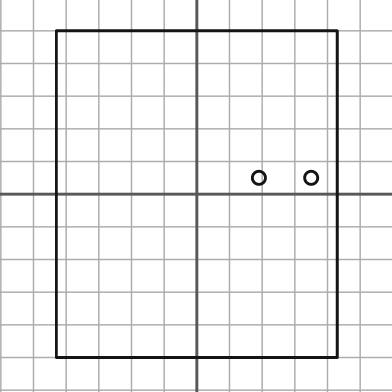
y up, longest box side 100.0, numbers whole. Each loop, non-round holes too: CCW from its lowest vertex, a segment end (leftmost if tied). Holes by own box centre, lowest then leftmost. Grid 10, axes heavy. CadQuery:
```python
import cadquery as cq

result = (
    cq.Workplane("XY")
    .moveTo(-43.0, -50.0)
    .lineTo(43.0, -50.0)
    .lineTo(43.0, 50.0)
    .lineTo(-43.0, 50.0)
    .close()
    .moveTo(19.0, 5.0)
    .circle(2.0)
    .moveTo(35.0, 5.0)
    .circle(2.0)
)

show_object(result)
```